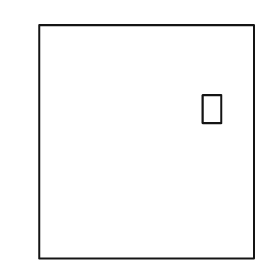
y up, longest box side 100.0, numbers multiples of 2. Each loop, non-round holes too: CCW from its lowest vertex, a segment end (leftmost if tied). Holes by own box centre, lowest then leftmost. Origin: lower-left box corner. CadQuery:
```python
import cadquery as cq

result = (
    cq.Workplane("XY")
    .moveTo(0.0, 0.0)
    .lineTo(92.0, 0.0)
    .lineTo(92.0, 100.0)
    .lineTo(0.0, 100.0)
    .close()
    .moveTo(70.0, 58.0)
    .lineTo(78.0, 58.0)
    .lineTo(78.0, 70.0)
    .lineTo(70.0, 70.0)
    .close()
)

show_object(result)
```